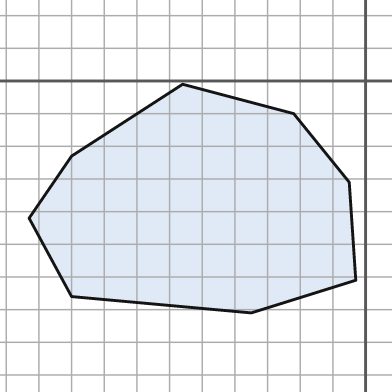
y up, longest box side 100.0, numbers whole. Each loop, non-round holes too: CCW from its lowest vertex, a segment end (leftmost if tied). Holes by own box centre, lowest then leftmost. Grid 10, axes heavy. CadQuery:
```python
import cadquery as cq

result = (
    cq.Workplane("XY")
    .moveTo(-35.0, -71.0)
    .lineTo(-3.0, -61.0)
    .lineTo(-5.0, -31.0)
    .lineTo(-22.0, -10.0)
    .lineTo(-56.0, -1.0)
    .lineTo(-90.0, -23.0)
    .lineTo(-103.0, -42.0)
    .lineTo(-90.0, -66.0)
    .close()
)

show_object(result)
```